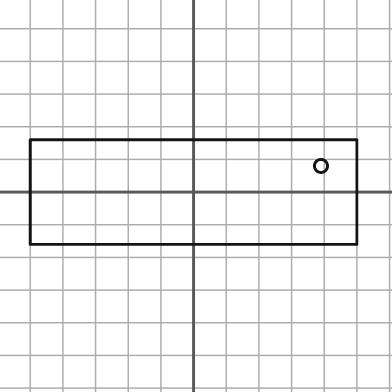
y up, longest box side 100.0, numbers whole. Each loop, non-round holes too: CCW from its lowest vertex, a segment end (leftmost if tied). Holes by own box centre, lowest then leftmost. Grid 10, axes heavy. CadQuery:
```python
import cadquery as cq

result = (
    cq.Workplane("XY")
    .moveTo(-50.0, -16.0)
    .lineTo(50.0, -16.0)
    .lineTo(50.0, 16.0)
    .lineTo(-50.0, 16.0)
    .close()
    .moveTo(39.0, 8.0)
    .circle(2.0)
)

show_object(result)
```